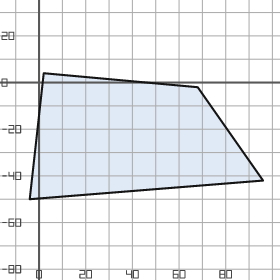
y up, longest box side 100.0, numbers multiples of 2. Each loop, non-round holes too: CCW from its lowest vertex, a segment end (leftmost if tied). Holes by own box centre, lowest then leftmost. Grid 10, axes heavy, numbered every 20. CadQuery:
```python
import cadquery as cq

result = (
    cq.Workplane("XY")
    .moveTo(-4.0, -50.0)
    .lineTo(96.0, -42.0)
    .lineTo(68.0, -2.0)
    .lineTo(2.0, 4.0)
    .close()
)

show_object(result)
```